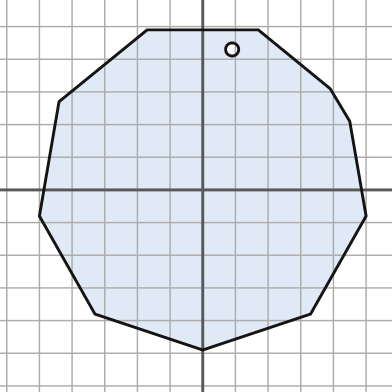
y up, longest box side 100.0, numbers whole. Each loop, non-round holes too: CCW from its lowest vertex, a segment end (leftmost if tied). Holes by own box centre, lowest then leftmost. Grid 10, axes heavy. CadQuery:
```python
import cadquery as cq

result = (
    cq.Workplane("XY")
    .moveTo(0.0, -49.0)
    .lineTo(33.0, -38.0)
    .lineTo(50.0, -8.0)
    .lineTo(45.0, 21.0)
    .lineTo(39.0, 31.0)
    .lineTo(17.0, 49.0)
    .lineTo(-17.0, 49.0)
    .lineTo(-44.0, 27.0)
    .lineTo(-50.0, -8.0)
    .lineTo(-33.0, -38.0)
    .close()
    .moveTo(9.0, 43.0)
    .circle(2.0)
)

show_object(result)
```